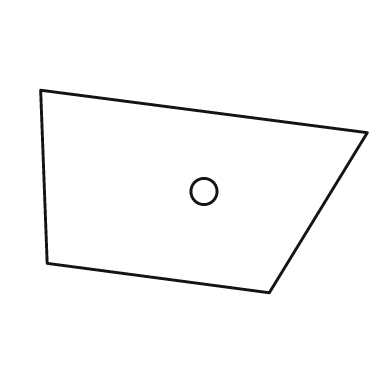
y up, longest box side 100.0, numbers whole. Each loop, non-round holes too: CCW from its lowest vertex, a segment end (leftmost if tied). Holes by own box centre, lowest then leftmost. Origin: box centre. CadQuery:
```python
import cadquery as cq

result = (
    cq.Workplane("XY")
    .moveTo(20.0, -31.0)
    .lineTo(50.0, 18.0)
    .lineTo(-50.0, 31.0)
    .lineTo(-48.0, -22.0)
    .close()
    .moveTo(0.0, 0.0)
    .circle(4.0)
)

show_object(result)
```